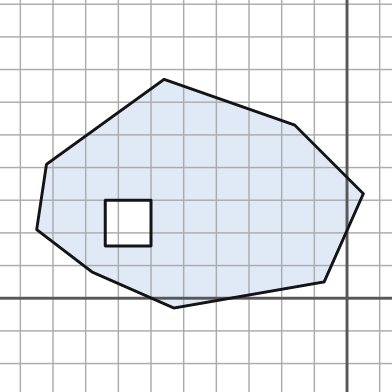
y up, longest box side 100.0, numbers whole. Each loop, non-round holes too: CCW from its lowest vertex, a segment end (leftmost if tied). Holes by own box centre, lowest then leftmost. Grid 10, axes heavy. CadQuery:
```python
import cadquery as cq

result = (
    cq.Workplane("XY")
    .moveTo(-53.0, -3.0)
    .lineTo(-7.0, 5.0)
    .lineTo(5.0, 32.0)
    .lineTo(-16.0, 53.0)
    .lineTo(-56.0, 67.0)
    .lineTo(-92.0, 41.0)
    .lineTo(-95.0, 21.0)
    .lineTo(-78.0, 8.0)
    .close()
    .moveTo(-74.0, 16.0)
    .lineTo(-60.0, 16.0)
    .lineTo(-60.0, 30.0)
    .lineTo(-74.0, 30.0)
    .close()
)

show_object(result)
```